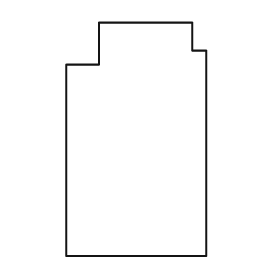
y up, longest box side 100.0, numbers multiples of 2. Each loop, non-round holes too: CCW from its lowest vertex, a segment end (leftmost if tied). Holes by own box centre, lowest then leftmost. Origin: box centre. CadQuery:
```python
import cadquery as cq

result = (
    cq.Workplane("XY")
    .moveTo(-30.0, -50.0)
    .lineTo(30.0, -50.0)
    .lineTo(30.0, 38.0)
    .lineTo(24.0, 38.0)
    .lineTo(24.0, 50.0)
    .lineTo(-16.0, 50.0)
    .lineTo(-16.0, 32.0)
    .lineTo(-30.0, 32.0)
    .close()
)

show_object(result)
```